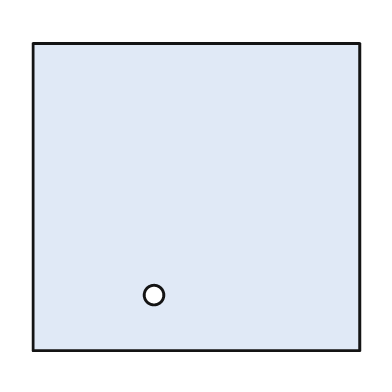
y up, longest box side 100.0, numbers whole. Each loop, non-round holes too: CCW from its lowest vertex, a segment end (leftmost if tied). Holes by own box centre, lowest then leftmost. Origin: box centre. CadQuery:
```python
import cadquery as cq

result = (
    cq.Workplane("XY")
    .moveTo(-50.0, -47.0)
    .lineTo(50.0, -47.0)
    .lineTo(50.0, 47.0)
    .lineTo(-50.0, 47.0)
    .close()
    .moveTo(-13.0, -30.0)
    .circle(3.0)
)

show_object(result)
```